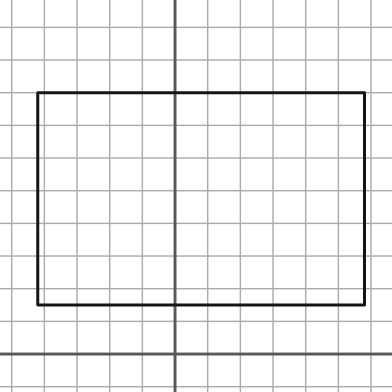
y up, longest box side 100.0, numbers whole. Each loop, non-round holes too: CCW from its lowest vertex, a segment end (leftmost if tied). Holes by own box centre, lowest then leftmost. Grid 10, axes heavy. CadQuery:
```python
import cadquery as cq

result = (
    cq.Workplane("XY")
    .moveTo(-42.0, 15.0)
    .lineTo(58.0, 15.0)
    .lineTo(58.0, 80.0)
    .lineTo(-42.0, 80.0)
    .close()
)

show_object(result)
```